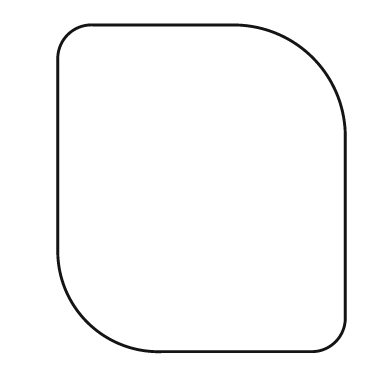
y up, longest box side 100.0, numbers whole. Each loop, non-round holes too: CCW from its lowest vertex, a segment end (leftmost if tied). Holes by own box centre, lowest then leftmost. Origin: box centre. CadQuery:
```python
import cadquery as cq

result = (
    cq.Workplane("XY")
    .moveTo(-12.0, -50.0)
    .lineTo(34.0, -50.0)
    .threePointArc((41.0, -47.0), (44.0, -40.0))
    .lineTo(44.0, 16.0)
    .threePointArc((34.0, 40.0), (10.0, 50.0))
    .lineTo(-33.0, 50.0)
    .threePointArc((-41.0, 47.0), (-44.0, 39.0))
    .lineTo(-44.0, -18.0)
    .threePointArc((-35.0, -41.0), (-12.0, -50.0))
    .close()
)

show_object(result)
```